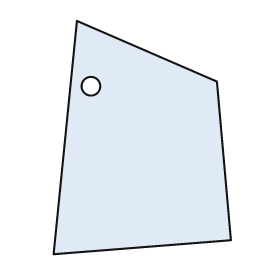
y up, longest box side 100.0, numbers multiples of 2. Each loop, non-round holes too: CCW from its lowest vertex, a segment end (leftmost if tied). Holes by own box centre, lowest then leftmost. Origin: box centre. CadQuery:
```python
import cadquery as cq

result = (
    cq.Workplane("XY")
    .moveTo(-38.0, -50.0)
    .lineTo(38.0, -44.0)
    .lineTo(32.0, 24.0)
    .lineTo(-28.0, 50.0)
    .close()
    .moveTo(-22.0, 22.0)
    .circle(4.0)
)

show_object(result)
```